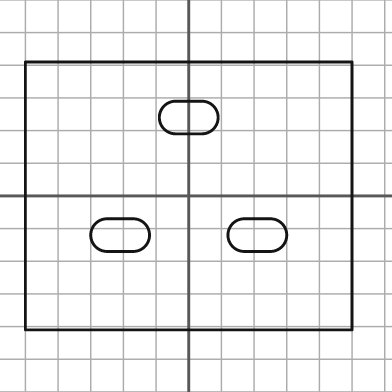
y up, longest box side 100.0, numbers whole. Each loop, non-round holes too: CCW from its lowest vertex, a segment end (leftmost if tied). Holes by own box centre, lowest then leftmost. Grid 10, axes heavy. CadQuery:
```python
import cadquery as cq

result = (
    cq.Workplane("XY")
    .moveTo(-50.0, -41.0)
    .lineTo(50.0, -41.0)
    .lineTo(50.0, 41.0)
    .lineTo(-50.0, 41.0)
    .close()
    .moveTo(-25.0, -17.0)
    .lineTo(-17.0, -17.0)
    .threePointArc((-12.0, -12.0), (-17.0, -7.0))
    .lineTo(-25.0, -7.0)
    .threePointArc((-30.0, -12.0), (-25.0, -17.0))
    .close()
    .moveTo(17.0, -17.0)
    .lineTo(25.0, -17.0)
    .threePointArc((30.0, -12.0), (25.0, -7.0))
    .lineTo(17.0, -7.0)
    .threePointArc((12.0, -12.0), (17.0, -17.0))
    .close()
    .moveTo(-4.0, 19.0)
    .lineTo(4.0, 19.0)
    .threePointArc((9.0, 24.0), (4.0, 29.0))
    .lineTo(-4.0, 29.0)
    .threePointArc((-9.0, 24.0), (-4.0, 19.0))
    .close()
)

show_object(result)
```